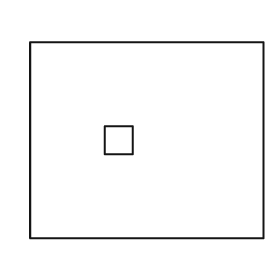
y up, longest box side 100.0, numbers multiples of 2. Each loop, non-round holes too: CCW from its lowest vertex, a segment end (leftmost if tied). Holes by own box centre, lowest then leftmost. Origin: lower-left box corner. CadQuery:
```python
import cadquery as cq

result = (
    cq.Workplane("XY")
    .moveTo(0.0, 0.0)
    .lineTo(100.0, 0.0)
    .lineTo(100.0, 84.0)
    .lineTo(0.0, 84.0)
    .close()
    .moveTo(32.0, 36.0)
    .lineTo(44.0, 36.0)
    .lineTo(44.0, 48.0)
    .lineTo(32.0, 48.0)
    .close()
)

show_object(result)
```